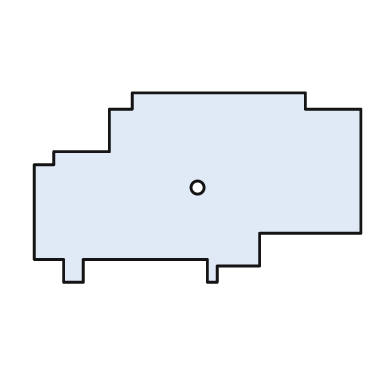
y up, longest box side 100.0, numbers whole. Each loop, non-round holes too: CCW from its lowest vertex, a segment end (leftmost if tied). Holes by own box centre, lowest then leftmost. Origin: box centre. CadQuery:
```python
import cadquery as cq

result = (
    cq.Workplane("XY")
    .moveTo(-41.0, -29.0)
    .lineTo(-35.0, -29.0)
    .lineTo(-35.0, -22.0)
    .lineTo(3.0, -22.0)
    .lineTo(3.0, -29.0)
    .lineTo(6.0, -29.0)
    .lineTo(6.0, -24.0)
    .lineTo(19.0, -24.0)
    .lineTo(19.0, -14.0)
    .lineTo(50.0, -14.0)
    .lineTo(50.0, 24.0)
    .lineTo(33.0, 24.0)
    .lineTo(33.0, 29.0)
    .lineTo(-20.0, 29.0)
    .lineTo(-20.0, 24.0)
    .lineTo(-27.0, 24.0)
    .lineTo(-27.0, 11.0)
    .lineTo(-44.0, 11.0)
    .lineTo(-44.0, 7.0)
    .lineTo(-50.0, 7.0)
    .lineTo(-50.0, -22.0)
    .lineTo(-41.0, -22.0)
    .close()
    .moveTo(0.0, 0.0)
    .circle(2.0)
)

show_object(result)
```